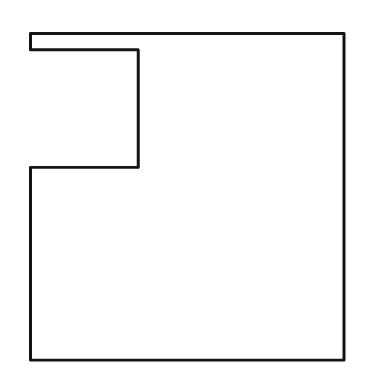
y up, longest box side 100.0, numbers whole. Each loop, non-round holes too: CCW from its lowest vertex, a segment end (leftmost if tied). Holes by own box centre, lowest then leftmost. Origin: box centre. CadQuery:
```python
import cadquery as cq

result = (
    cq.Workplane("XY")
    .moveTo(-48.0, -50.0)
    .lineTo(48.0, -50.0)
    .lineTo(48.0, 50.0)
    .lineTo(-48.0, 50.0)
    .lineTo(-48.0, 45.0)
    .lineTo(-15.0, 45.0)
    .lineTo(-15.0, 9.0)
    .lineTo(-48.0, 9.0)
    .close()
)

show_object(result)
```